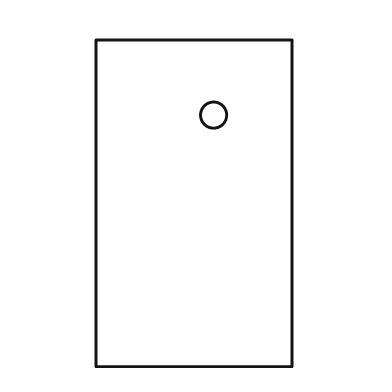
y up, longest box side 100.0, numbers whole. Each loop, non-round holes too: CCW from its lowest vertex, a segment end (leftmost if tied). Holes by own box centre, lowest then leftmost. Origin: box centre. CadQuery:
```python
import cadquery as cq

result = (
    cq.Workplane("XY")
    .moveTo(-30.0, -50.0)
    .lineTo(30.0, -50.0)
    .lineTo(30.0, 50.0)
    .lineTo(-30.0, 50.0)
    .close()
    .moveTo(6.0, 27.0)
    .circle(4.0)
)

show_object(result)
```